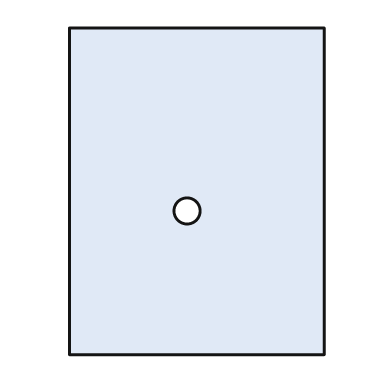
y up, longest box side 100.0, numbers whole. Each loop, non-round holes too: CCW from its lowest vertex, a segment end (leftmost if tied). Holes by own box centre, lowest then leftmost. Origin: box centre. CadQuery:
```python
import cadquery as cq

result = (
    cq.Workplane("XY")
    .moveTo(-39.0, -50.0)
    .lineTo(39.0, -50.0)
    .lineTo(39.0, 50.0)
    .lineTo(-39.0, 50.0)
    .close()
    .moveTo(-3.0, -6.0)
    .circle(4.0)
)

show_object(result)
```